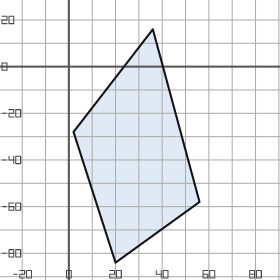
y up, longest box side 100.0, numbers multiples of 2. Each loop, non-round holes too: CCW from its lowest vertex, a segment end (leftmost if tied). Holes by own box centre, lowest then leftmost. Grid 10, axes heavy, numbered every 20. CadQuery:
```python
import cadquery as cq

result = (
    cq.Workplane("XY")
    .moveTo(20.0, -84.0)
    .lineTo(56.0, -58.0)
    .lineTo(36.0, 16.0)
    .lineTo(2.0, -28.0)
    .close()
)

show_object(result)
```